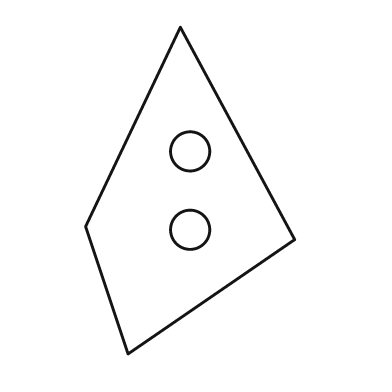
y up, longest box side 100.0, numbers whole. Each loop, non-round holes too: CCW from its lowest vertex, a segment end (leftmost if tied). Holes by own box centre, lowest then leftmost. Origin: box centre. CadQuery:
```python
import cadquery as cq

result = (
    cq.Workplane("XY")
    .moveTo(-19.0, -50.0)
    .lineTo(32.0, -15.0)
    .lineTo(-3.0, 50.0)
    .lineTo(-32.0, -11.0)
    .close()
    .moveTo(0.0, -12.0)
    .circle(6.0)
    .moveTo(0.0, 12.0)
    .circle(6.0)
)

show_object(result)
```